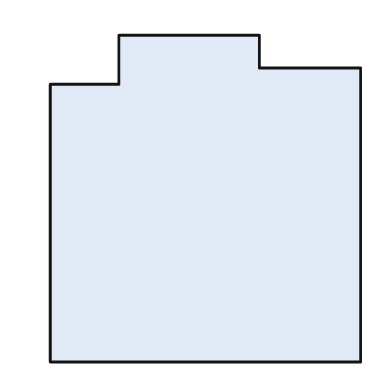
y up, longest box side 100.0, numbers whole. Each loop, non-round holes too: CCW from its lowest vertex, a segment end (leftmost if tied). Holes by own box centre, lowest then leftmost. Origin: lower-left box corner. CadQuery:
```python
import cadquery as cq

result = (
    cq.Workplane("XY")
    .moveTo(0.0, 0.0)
    .lineTo(95.0, 0.0)
    .lineTo(95.0, 90.0)
    .lineTo(64.0, 90.0)
    .lineTo(64.0, 100.0)
    .lineTo(21.0, 100.0)
    .lineTo(21.0, 85.0)
    .lineTo(0.0, 85.0)
    .close()
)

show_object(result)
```